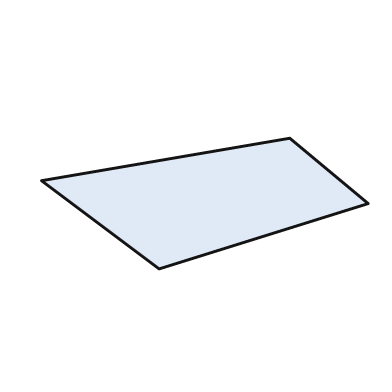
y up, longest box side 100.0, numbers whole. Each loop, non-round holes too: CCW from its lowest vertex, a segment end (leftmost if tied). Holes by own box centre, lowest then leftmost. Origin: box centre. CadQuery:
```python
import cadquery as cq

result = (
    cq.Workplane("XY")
    .moveTo(-14.0, -20.0)
    .lineTo(50.0, 0.0)
    .lineTo(26.0, 20.0)
    .lineTo(-50.0, 7.0)
    .close()
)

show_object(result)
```